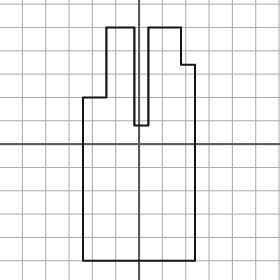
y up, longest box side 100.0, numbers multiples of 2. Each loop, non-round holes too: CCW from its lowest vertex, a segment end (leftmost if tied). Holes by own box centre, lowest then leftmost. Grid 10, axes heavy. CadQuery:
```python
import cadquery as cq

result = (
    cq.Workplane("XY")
    .moveTo(-24.0, -50.0)
    .lineTo(24.0, -50.0)
    .lineTo(24.0, 34.0)
    .lineTo(18.0, 34.0)
    .lineTo(18.0, 50.0)
    .lineTo(4.0, 50.0)
    .lineTo(4.0, 8.0)
    .lineTo(-2.0, 8.0)
    .lineTo(-2.0, 50.0)
    .lineTo(-14.0, 50.0)
    .lineTo(-14.0, 20.0)
    .lineTo(-24.0, 20.0)
    .close()
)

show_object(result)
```